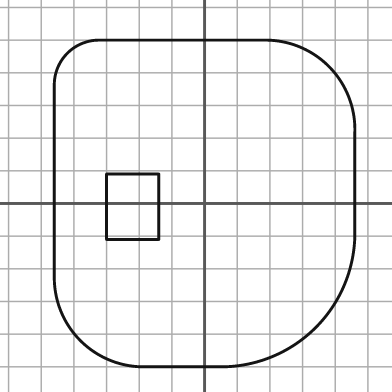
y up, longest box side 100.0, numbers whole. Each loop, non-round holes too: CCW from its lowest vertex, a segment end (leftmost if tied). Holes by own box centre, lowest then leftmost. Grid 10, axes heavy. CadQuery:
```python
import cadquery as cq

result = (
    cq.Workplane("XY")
    .moveTo(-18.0, -50.0)
    .lineTo(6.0, -50.0)
    .threePointArc((34.0, -38.0), (46.0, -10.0))
    .lineTo(46.0, 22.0)
    .threePointArc((38.0, 42.0), (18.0, 50.0))
    .lineTo(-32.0, 50.0)
    .threePointArc((-42.0, 46.0), (-46.0, 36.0))
    .lineTo(-46.0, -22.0)
    .threePointArc((-38.0, -42.0), (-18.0, -50.0))
    .close()
    .moveTo(-30.0, -11.0)
    .lineTo(-14.0, -11.0)
    .lineTo(-14.0, 9.0)
    .lineTo(-30.0, 9.0)
    .close()
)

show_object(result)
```